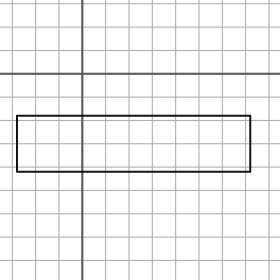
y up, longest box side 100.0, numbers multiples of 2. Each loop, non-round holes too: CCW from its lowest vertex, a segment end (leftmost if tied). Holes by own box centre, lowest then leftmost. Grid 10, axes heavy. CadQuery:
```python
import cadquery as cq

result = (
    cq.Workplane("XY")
    .moveTo(-28.0, -42.0)
    .lineTo(72.0, -42.0)
    .lineTo(72.0, -18.0)
    .lineTo(-28.0, -18.0)
    .close()
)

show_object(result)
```